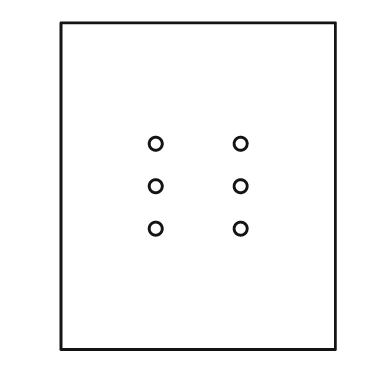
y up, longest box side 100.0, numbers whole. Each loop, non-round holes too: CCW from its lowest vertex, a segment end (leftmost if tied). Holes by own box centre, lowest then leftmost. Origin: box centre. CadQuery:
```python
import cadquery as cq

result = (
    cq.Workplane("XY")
    .moveTo(-42.0, -50.0)
    .lineTo(42.0, -50.0)
    .lineTo(42.0, 50.0)
    .lineTo(-42.0, 50.0)
    .close()
    .moveTo(-13.0, -13.0)
    .circle(2.0)
    .moveTo(13.0, -13.0)
    .circle(2.0)
    .moveTo(-13.0, 0.0)
    .circle(2.0)
    .moveTo(13.0, 0.0)
    .circle(2.0)
    .moveTo(-13.0, 13.0)
    .circle(2.0)
    .moveTo(13.0, 13.0)
    .circle(2.0)
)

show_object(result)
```